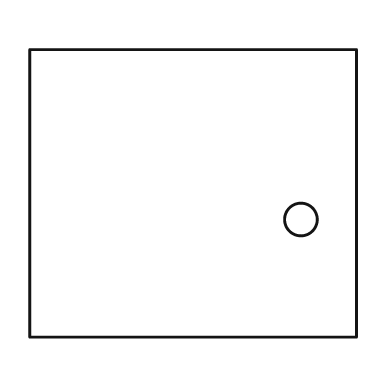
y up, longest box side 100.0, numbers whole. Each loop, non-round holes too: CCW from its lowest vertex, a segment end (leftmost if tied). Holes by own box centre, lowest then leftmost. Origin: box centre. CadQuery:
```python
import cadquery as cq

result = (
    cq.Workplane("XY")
    .moveTo(-50.0, -44.0)
    .lineTo(50.0, -44.0)
    .lineTo(50.0, 44.0)
    .lineTo(-50.0, 44.0)
    .close()
    .moveTo(33.0, -8.0)
    .circle(5.0)
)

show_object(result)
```